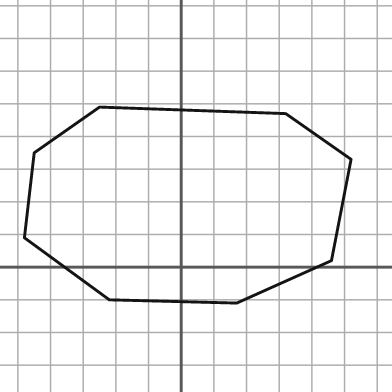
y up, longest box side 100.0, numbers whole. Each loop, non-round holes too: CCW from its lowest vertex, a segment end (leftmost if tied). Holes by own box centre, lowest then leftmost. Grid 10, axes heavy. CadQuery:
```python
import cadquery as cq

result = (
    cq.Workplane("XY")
    .moveTo(17.0, -11.0)
    .lineTo(46.0, 2.0)
    .lineTo(52.0, 33.0)
    .lineTo(32.0, 47.0)
    .lineTo(-25.0, 49.0)
    .lineTo(-45.0, 35.0)
    .lineTo(-48.0, 9.0)
    .lineTo(-22.0, -10.0)
    .close()
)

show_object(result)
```